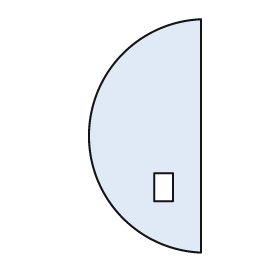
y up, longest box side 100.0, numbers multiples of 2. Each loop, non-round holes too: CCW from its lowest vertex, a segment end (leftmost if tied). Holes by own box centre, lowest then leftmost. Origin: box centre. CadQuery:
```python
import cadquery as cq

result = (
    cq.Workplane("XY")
    .moveTo(24.0, -50.0)
    .lineTo(24.0, 50.0)
    .threePointArc((-24.0, 0.0), (24.0, -50.0))
    .close()
    .moveTo(4.0, -28.0)
    .lineTo(12.0, -28.0)
    .lineTo(12.0, -16.0)
    .lineTo(4.0, -16.0)
    .close()
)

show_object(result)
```